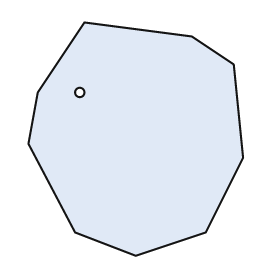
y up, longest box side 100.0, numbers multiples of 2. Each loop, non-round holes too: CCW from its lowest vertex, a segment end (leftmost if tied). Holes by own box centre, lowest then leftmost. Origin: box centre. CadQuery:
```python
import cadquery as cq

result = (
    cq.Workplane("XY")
    .moveTo(0.0, -50.0)
    .lineTo(30.0, -40.0)
    .lineTo(46.0, -8.0)
    .lineTo(42.0, 32.0)
    .lineTo(24.0, 44.0)
    .lineTo(-22.0, 50.0)
    .lineTo(-42.0, 20.0)
    .lineTo(-46.0, -2.0)
    .lineTo(-26.0, -40.0)
    .close()
    .moveTo(-24.0, 20.0)
    .circle(2.0)
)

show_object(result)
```